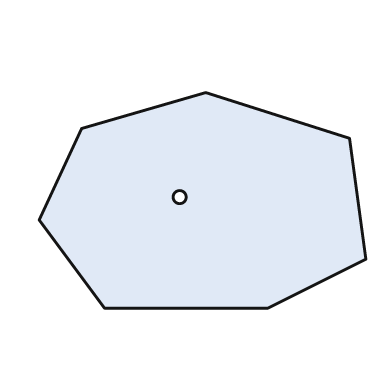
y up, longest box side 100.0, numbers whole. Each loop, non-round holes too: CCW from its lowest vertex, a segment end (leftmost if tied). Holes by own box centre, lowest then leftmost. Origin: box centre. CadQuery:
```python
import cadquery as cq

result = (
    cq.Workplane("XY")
    .moveTo(-30.0, -33.0)
    .lineTo(20.0, -33.0)
    .lineTo(50.0, -18.0)
    .lineTo(45.0, 19.0)
    .lineTo(1.0, 33.0)
    .lineTo(-37.0, 22.0)
    .lineTo(-50.0, -6.0)
    .close()
    .moveTo(-7.0, 1.0)
    .circle(2.0)
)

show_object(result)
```